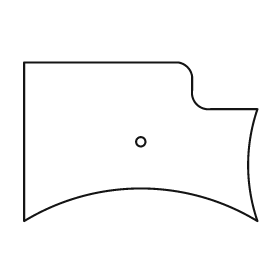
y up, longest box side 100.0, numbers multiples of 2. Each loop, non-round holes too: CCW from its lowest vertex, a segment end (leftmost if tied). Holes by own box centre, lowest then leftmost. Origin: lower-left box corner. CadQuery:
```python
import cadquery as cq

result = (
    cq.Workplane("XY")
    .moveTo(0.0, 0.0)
    .threePointArc((50.0, 14.0), (100.0, 0.0))
    .threePointArc((96.0, 24.0), (100.0, 48.0))
    .lineTo(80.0, 48.0)
    .threePointArc((74.0, 50.0), (72.0, 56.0))
    .lineTo(72.0, 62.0)
    .threePointArc((70.0, 66.0), (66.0, 68.0))
    .lineTo(0.0, 68.0)
    .close()
    .moveTo(50.0, 34.0)
    .circle(2.0)
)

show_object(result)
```